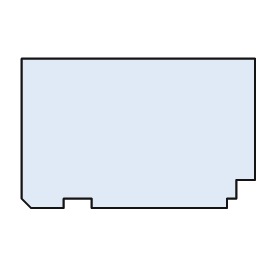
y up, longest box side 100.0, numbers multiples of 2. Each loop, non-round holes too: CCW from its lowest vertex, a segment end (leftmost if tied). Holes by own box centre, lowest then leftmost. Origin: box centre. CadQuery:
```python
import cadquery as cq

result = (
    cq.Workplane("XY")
    .moveTo(-46.0, -32.0)
    .lineTo(-32.0, -32.0)
    .lineTo(-32.0, -28.0)
    .lineTo(-20.0, -28.0)
    .lineTo(-20.0, -32.0)
    .lineTo(38.0, -32.0)
    .lineTo(38.0, -28.0)
    .lineTo(42.0, -28.0)
    .lineTo(42.0, -20.0)
    .lineTo(50.0, -20.0)
    .lineTo(50.0, 32.0)
    .lineTo(-50.0, 32.0)
    .lineTo(-50.0, -28.0)
    .close()
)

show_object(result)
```